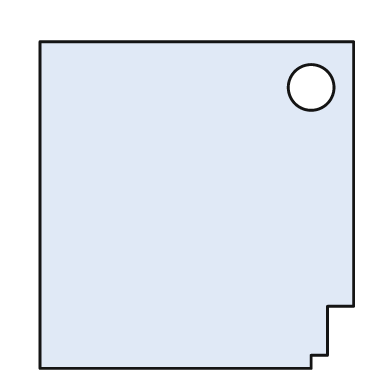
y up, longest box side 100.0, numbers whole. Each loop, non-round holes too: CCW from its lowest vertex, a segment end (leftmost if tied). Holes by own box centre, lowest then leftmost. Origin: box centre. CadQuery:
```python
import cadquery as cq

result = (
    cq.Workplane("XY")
    .moveTo(-48.0, -50.0)
    .lineTo(35.0, -50.0)
    .lineTo(35.0, -46.0)
    .lineTo(40.0, -46.0)
    .lineTo(40.0, -31.0)
    .lineTo(48.0, -31.0)
    .lineTo(48.0, 50.0)
    .lineTo(-48.0, 50.0)
    .close()
    .moveTo(35.0, 36.0)
    .circle(7.0)
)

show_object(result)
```